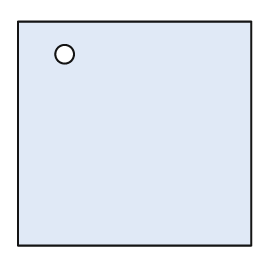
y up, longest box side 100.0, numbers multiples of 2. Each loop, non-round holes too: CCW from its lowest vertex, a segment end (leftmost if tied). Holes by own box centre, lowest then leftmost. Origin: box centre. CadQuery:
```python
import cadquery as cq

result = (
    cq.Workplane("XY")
    .moveTo(-50.0, -48.0)
    .lineTo(50.0, -48.0)
    .lineTo(50.0, 48.0)
    .lineTo(-50.0, 48.0)
    .close()
    .moveTo(-30.0, 34.0)
    .circle(4.0)
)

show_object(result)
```